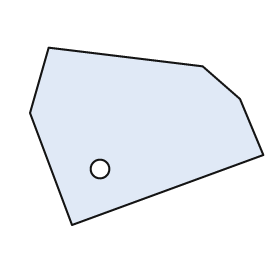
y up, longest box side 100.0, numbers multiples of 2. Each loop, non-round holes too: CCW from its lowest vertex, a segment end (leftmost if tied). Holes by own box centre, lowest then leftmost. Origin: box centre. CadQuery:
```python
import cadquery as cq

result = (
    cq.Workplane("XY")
    .moveTo(-32.0, -38.0)
    .lineTo(50.0, -8.0)
    .lineTo(40.0, 16.0)
    .lineTo(24.0, 30.0)
    .lineTo(-42.0, 38.0)
    .lineTo(-50.0, 10.0)
    .close()
    .moveTo(-20.0, -14.0)
    .circle(4.0)
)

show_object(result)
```